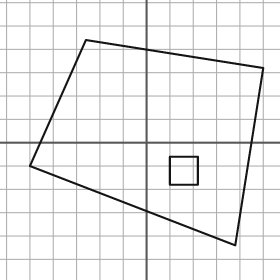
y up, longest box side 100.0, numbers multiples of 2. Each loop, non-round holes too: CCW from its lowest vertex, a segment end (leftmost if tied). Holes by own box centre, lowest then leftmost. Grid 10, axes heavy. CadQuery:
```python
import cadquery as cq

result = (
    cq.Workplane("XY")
    .moveTo(38.0, -44.0)
    .lineTo(50.0, 32.0)
    .lineTo(-26.0, 44.0)
    .lineTo(-50.0, -10.0)
    .close()
    .moveTo(10.0, -18.0)
    .lineTo(22.0, -18.0)
    .lineTo(22.0, -6.0)
    .lineTo(10.0, -6.0)
    .close()
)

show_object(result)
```